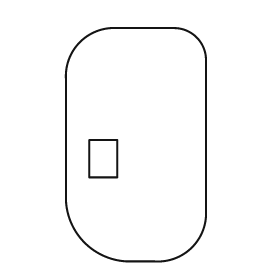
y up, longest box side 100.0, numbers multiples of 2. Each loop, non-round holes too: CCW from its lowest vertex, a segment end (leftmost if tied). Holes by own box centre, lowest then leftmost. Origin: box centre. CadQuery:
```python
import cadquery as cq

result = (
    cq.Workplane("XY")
    .moveTo(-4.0, -50.0)
    .lineTo(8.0, -50.0)
    .threePointArc((24.0, -44.0), (30.0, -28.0))
    .lineTo(30.0, 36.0)
    .threePointArc((26.0, 46.0), (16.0, 50.0))
    .lineTo(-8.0, 50.0)
    .threePointArc((-24.0, 44.0), (-30.0, 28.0))
    .lineTo(-30.0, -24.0)
    .threePointArc((-22.0, -42.0), (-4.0, -50.0))
    .close()
    .moveTo(-20.0, -14.0)
    .lineTo(-8.0, -14.0)
    .lineTo(-8.0, 2.0)
    .lineTo(-20.0, 2.0)
    .close()
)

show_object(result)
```